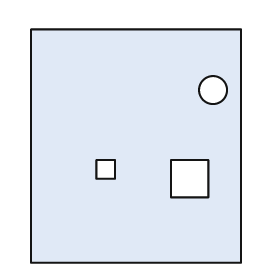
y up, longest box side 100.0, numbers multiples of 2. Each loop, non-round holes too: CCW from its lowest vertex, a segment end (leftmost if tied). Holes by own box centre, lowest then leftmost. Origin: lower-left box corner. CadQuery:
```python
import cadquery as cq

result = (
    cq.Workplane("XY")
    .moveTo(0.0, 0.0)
    .lineTo(90.0, 0.0)
    .lineTo(90.0, 100.0)
    .lineTo(0.0, 100.0)
    .close()
    .moveTo(60.0, 28.0)
    .lineTo(76.0, 28.0)
    .lineTo(76.0, 44.0)
    .lineTo(60.0, 44.0)
    .close()
    .moveTo(28.0, 36.0)
    .lineTo(36.0, 36.0)
    .lineTo(36.0, 44.0)
    .lineTo(28.0, 44.0)
    .close()
    .moveTo(78.0, 74.0)
    .circle(6.0)
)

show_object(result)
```